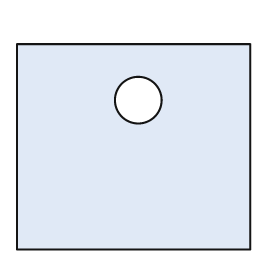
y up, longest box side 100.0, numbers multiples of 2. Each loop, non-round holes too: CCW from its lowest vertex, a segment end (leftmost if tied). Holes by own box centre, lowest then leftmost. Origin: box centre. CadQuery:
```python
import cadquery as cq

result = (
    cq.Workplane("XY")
    .moveTo(-50.0, -44.0)
    .lineTo(50.0, -44.0)
    .lineTo(50.0, 44.0)
    .lineTo(-50.0, 44.0)
    .close()
    .moveTo(2.0, 20.0)
    .circle(10.0)
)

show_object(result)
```